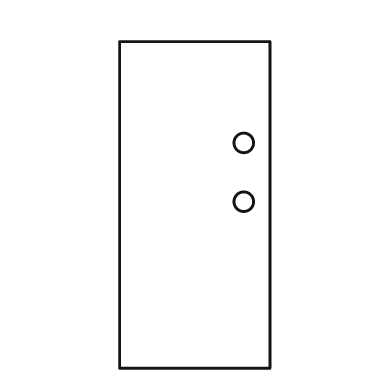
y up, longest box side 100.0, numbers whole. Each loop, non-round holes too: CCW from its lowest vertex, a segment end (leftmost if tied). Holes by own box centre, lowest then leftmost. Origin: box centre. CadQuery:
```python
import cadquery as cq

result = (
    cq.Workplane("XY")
    .moveTo(-23.0, -50.0)
    .lineTo(23.0, -50.0)
    .lineTo(23.0, 50.0)
    .lineTo(-23.0, 50.0)
    .close()
    .moveTo(15.0, 1.0)
    .circle(3.0)
    .moveTo(15.0, 19.0)
    .circle(3.0)
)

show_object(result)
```